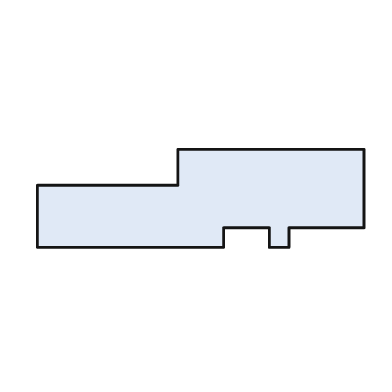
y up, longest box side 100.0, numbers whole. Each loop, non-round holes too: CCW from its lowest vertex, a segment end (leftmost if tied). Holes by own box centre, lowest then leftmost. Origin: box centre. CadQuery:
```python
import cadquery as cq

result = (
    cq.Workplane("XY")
    .moveTo(-50.0, -15.0)
    .lineTo(7.0, -15.0)
    .lineTo(7.0, -9.0)
    .lineTo(21.0, -9.0)
    .lineTo(21.0, -15.0)
    .lineTo(27.0, -15.0)
    .lineTo(27.0, -9.0)
    .lineTo(50.0, -9.0)
    .lineTo(50.0, 15.0)
    .lineTo(-7.0, 15.0)
    .lineTo(-7.0, 4.0)
    .lineTo(-50.0, 4.0)
    .close()
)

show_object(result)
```